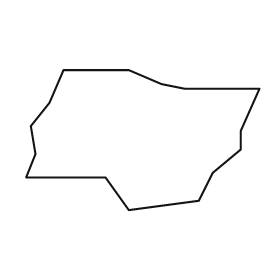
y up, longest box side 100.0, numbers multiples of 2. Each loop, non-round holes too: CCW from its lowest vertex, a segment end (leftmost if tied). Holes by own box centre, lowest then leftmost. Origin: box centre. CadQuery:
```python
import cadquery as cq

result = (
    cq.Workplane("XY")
    .moveTo(-6.0, -30.0)
    .lineTo(24.0, -26.0)
    .lineTo(30.0, -14.0)
    .lineTo(42.0, -4.0)
    .lineTo(42.0, 4.0)
    .lineTo(50.0, 22.0)
    .lineTo(18.0, 22.0)
    .lineTo(8.0, 24.0)
    .lineTo(-6.0, 30.0)
    .lineTo(-34.0, 30.0)
    .lineTo(-40.0, 16.0)
    .lineTo(-48.0, 6.0)
    .lineTo(-46.0, -6.0)
    .lineTo(-50.0, -16.0)
    .lineTo(-16.0, -16.0)
    .close()
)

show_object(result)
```